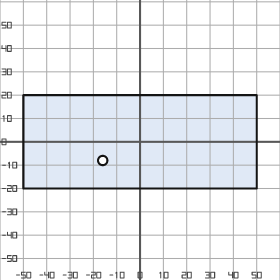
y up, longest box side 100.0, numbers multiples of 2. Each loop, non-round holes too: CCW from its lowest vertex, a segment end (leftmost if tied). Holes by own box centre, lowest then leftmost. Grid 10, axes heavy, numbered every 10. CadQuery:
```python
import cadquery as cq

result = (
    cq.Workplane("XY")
    .moveTo(-50.0, -20.0)
    .lineTo(50.0, -20.0)
    .lineTo(50.0, 20.0)
    .lineTo(-50.0, 20.0)
    .close()
    .moveTo(-16.0, -8.0)
    .circle(2.0)
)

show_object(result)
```